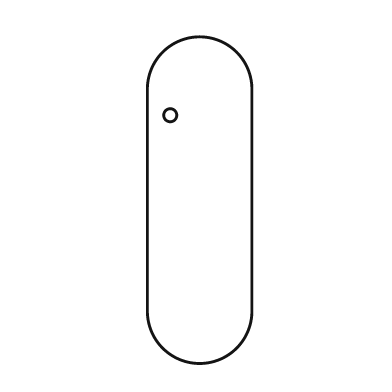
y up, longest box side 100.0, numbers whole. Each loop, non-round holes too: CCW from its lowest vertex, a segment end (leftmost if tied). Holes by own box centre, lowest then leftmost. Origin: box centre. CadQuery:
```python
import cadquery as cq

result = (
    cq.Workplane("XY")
    .moveTo(-16.0, -34.0)
    .threePointArc((0.0, -50.0), (16.0, -34.0))
    .lineTo(16.0, 34.0)
    .threePointArc((0.0, 50.0), (-16.0, 34.0))
    .close()
    .moveTo(-9.0, 26.0)
    .circle(2.0)
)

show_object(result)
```